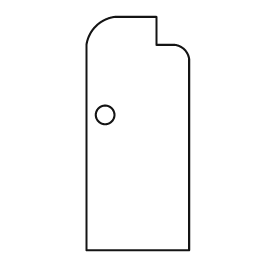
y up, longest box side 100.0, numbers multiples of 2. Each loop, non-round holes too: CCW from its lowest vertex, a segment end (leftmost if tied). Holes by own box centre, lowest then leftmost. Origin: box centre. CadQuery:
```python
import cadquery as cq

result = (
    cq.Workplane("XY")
    .moveTo(-22.0, -50.0)
    .lineTo(22.0, -50.0)
    .lineTo(22.0, 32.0)
    .threePointArc((20.0, 36.0), (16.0, 38.0))
    .lineTo(8.0, 38.0)
    .lineTo(8.0, 50.0)
    .lineTo(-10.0, 50.0)
    .threePointArc((-18.0, 46.0), (-22.0, 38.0))
    .close()
    .moveTo(-14.0, 8.0)
    .circle(4.0)
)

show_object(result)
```